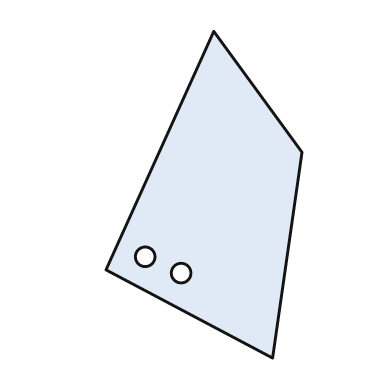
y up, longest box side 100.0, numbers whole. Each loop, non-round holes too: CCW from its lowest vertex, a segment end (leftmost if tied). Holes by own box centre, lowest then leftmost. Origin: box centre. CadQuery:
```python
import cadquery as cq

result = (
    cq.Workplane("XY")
    .moveTo(21.0, -50.0)
    .lineTo(30.0, 13.0)
    .lineTo(3.0, 50.0)
    .lineTo(-30.0, -23.0)
    .close()
    .moveTo(-7.0, -24.0)
    .circle(3.0)
    .moveTo(-18.0, -19.0)
    .circle(3.0)
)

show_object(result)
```